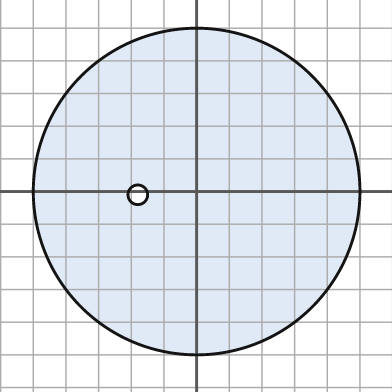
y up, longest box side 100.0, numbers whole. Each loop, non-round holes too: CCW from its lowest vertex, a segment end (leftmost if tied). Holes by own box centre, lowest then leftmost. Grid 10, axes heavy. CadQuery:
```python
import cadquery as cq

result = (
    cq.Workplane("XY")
    .moveTo(0.0, 0.0)
    .circle(50.0)
    .moveTo(-18.0, -1.0)
    .circle(3.0)
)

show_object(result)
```